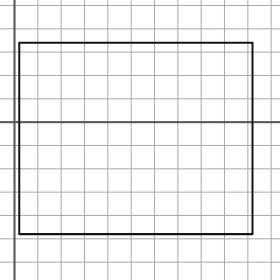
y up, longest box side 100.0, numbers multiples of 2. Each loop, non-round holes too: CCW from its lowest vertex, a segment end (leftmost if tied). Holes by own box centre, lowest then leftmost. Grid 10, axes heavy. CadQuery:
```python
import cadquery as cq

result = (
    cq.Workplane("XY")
    .moveTo(2.0, -48.0)
    .lineTo(102.0, -48.0)
    .lineTo(102.0, 34.0)
    .lineTo(2.0, 34.0)
    .close()
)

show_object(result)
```